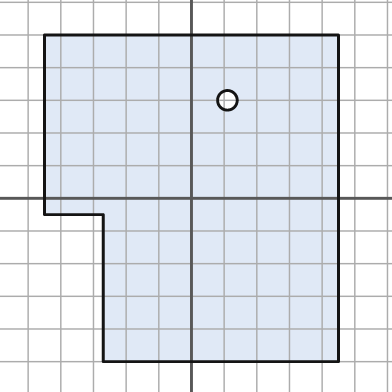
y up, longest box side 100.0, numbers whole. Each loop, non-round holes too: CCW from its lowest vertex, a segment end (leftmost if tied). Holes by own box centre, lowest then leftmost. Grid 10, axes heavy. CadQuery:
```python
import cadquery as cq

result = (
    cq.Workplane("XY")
    .moveTo(-27.0, -50.0)
    .lineTo(45.0, -50.0)
    .lineTo(45.0, 50.0)
    .lineTo(-45.0, 50.0)
    .lineTo(-45.0, -5.0)
    .lineTo(-27.0, -5.0)
    .close()
    .moveTo(11.0, 30.0)
    .circle(3.0)
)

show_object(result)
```